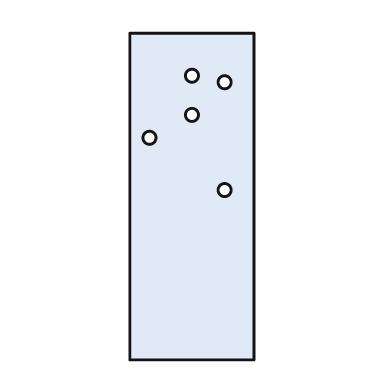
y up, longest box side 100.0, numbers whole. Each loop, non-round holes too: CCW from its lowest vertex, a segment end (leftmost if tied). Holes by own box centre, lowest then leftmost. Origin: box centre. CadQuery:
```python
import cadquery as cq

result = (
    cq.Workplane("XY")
    .moveTo(-19.0, -50.0)
    .lineTo(19.0, -50.0)
    .lineTo(19.0, 50.0)
    .lineTo(-19.0, 50.0)
    .close()
    .moveTo(10.0, 2.0)
    .circle(2.0)
    .moveTo(-13.0, 18.0)
    .circle(2.0)
    .moveTo(0.0, 25.0)
    .circle(2.0)
    .moveTo(10.0, 35.0)
    .circle(2.0)
    .moveTo(0.0, 37.0)
    .circle(2.0)
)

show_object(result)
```